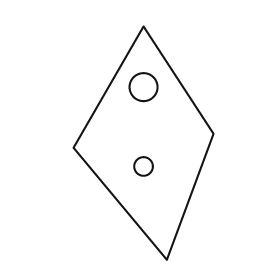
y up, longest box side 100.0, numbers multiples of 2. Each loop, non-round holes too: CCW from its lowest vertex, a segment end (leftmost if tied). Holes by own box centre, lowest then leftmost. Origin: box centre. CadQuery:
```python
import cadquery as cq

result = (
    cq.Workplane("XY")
    .moveTo(10.0, -50.0)
    .lineTo(30.0, 4.0)
    .lineTo(0.0, 50.0)
    .lineTo(-30.0, -2.0)
    .close()
    .moveTo(0.0, -10.0)
    .circle(4.0)
    .moveTo(0.0, 24.0)
    .circle(6.0)
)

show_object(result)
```